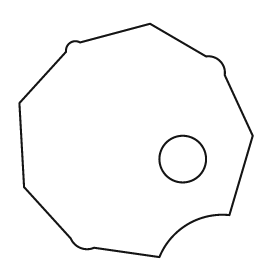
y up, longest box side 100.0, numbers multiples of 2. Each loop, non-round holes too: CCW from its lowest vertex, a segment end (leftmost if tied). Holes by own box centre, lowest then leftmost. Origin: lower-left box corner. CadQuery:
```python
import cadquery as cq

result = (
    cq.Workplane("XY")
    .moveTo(60.0, 0.0)
    .threePointArc((72.0, 14.0), (90.0, 18.0))
    .lineTo(100.0, 52.0)
    .lineTo(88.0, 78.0)
    .threePointArc((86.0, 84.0), (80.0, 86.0))
    .lineTo(56.0, 100.0)
    .lineTo(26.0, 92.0)
    .threePointArc((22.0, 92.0), (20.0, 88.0))
    .lineTo(0.0, 66.0)
    .lineTo(2.0, 30.0)
    .lineTo(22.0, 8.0)
    .threePointArc((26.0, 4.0), (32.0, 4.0))
    .close()
    .moveTo(70.0, 42.0)
    .circle(10.0)
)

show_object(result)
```